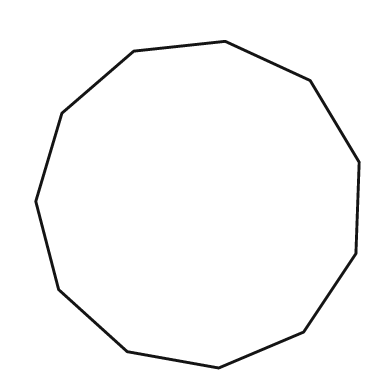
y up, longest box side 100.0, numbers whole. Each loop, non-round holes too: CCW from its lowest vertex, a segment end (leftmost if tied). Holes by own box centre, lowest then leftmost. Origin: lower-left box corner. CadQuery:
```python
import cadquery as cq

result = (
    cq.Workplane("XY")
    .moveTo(56.0, 0.0)
    .lineTo(82.0, 11.0)
    .lineTo(98.0, 35.0)
    .lineTo(99.0, 63.0)
    .lineTo(84.0, 88.0)
    .lineTo(58.0, 100.0)
    .lineTo(30.0, 97.0)
    .lineTo(8.0, 78.0)
    .lineTo(0.0, 51.0)
    .lineTo(7.0, 24.0)
    .lineTo(28.0, 5.0)
    .close()
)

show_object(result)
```